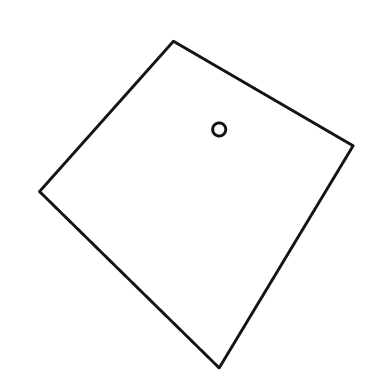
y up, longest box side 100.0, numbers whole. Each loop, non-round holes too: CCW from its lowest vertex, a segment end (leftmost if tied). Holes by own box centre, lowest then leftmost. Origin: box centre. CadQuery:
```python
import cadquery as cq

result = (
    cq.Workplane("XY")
    .moveTo(7.0, -50.0)
    .lineTo(48.0, 18.0)
    .lineTo(-7.0, 50.0)
    .lineTo(-48.0, 4.0)
    .close()
    .moveTo(7.0, 23.0)
    .circle(2.0)
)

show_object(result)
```